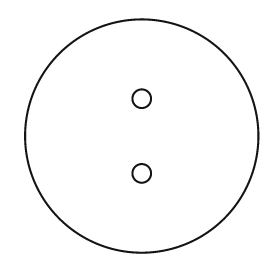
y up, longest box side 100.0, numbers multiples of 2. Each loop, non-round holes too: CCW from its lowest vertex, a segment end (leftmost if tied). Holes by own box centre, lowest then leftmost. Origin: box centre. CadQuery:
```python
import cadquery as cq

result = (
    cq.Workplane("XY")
    .moveTo(0.0, 0.0)
    .circle(50.0)
    .moveTo(0.0, -16.0)
    .circle(4.0)
    .moveTo(0.0, 16.0)
    .circle(4.0)
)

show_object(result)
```